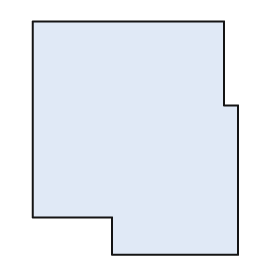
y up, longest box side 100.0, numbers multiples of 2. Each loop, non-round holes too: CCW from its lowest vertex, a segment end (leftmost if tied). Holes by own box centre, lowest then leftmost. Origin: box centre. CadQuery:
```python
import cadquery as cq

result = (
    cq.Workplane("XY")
    .moveTo(-10.0, -50.0)
    .lineTo(44.0, -50.0)
    .lineTo(44.0, 14.0)
    .lineTo(38.0, 14.0)
    .lineTo(38.0, 50.0)
    .lineTo(-44.0, 50.0)
    .lineTo(-44.0, -34.0)
    .lineTo(-10.0, -34.0)
    .close()
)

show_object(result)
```